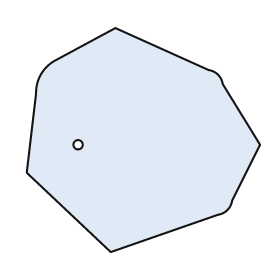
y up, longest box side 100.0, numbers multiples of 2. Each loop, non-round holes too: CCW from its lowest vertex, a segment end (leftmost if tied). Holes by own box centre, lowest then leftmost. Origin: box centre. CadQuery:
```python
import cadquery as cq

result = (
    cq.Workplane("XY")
    .moveTo(-14.0, -48.0)
    .lineTo(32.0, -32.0)
    .threePointArc((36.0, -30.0), (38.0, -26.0))
    .lineTo(50.0, -2.0)
    .lineTo(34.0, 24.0)
    .threePointArc((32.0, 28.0), (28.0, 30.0))
    .lineTo(-12.0, 48.0)
    .lineTo(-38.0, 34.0)
    .threePointArc((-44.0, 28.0), (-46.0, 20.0))
    .lineTo(-50.0, -14.0)
    .close()
    .moveTo(-28.0, -2.0)
    .circle(2.0)
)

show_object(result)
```